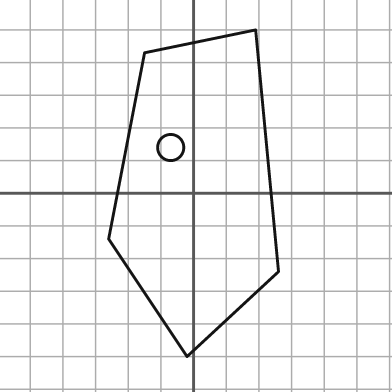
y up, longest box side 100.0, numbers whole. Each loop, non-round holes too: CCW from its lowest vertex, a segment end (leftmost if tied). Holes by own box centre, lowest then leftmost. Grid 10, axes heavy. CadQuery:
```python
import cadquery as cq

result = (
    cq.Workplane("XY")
    .moveTo(-2.0, -50.0)
    .lineTo(26.0, -24.0)
    .lineTo(19.0, 50.0)
    .lineTo(-15.0, 43.0)
    .lineTo(-26.0, -14.0)
    .close()
    .moveTo(-7.0, 14.0)
    .circle(4.0)
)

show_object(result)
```